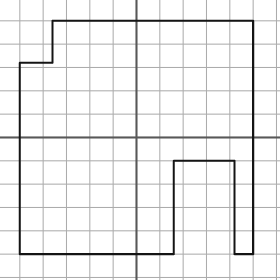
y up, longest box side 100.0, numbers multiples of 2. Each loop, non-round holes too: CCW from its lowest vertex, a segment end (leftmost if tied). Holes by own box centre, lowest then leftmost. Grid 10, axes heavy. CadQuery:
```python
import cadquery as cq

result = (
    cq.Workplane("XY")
    .moveTo(-50.0, -50.0)
    .lineTo(16.0, -50.0)
    .lineTo(16.0, -10.0)
    .lineTo(42.0, -10.0)
    .lineTo(42.0, -50.0)
    .lineTo(50.0, -50.0)
    .lineTo(50.0, 50.0)
    .lineTo(-36.0, 50.0)
    .lineTo(-36.0, 32.0)
    .lineTo(-50.0, 32.0)
    .close()
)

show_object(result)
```